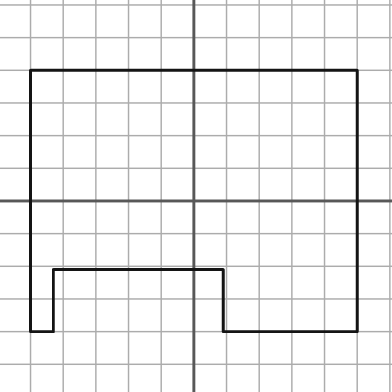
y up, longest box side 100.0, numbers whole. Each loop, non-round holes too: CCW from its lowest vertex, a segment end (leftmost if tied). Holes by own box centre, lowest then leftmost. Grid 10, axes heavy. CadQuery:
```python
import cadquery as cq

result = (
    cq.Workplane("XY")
    .moveTo(-50.0, -40.0)
    .lineTo(-43.0, -40.0)
    .lineTo(-43.0, -21.0)
    .lineTo(9.0, -21.0)
    .lineTo(9.0, -40.0)
    .lineTo(50.0, -40.0)
    .lineTo(50.0, 40.0)
    .lineTo(-50.0, 40.0)
    .close()
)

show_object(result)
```